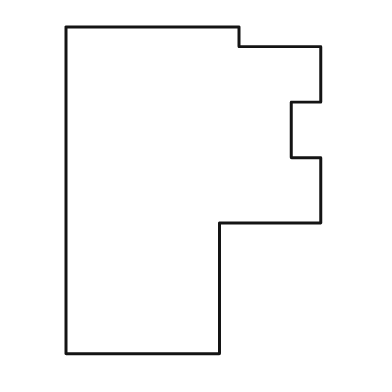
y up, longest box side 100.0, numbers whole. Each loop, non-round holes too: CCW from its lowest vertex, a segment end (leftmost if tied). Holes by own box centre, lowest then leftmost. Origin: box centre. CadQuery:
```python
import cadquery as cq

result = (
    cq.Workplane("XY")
    .moveTo(-39.0, -50.0)
    .lineTo(8.0, -50.0)
    .lineTo(8.0, -10.0)
    .lineTo(39.0, -10.0)
    .lineTo(39.0, 10.0)
    .lineTo(30.0, 10.0)
    .lineTo(30.0, 27.0)
    .lineTo(39.0, 27.0)
    .lineTo(39.0, 44.0)
    .lineTo(14.0, 44.0)
    .lineTo(14.0, 50.0)
    .lineTo(-39.0, 50.0)
    .close()
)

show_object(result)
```